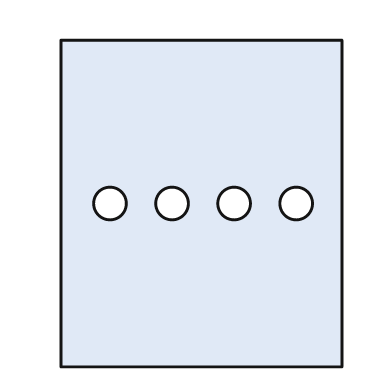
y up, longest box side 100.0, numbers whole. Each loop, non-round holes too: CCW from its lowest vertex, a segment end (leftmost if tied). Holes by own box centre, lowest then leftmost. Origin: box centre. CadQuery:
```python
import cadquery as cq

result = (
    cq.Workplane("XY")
    .moveTo(-43.0, -50.0)
    .lineTo(43.0, -50.0)
    .lineTo(43.0, 50.0)
    .lineTo(-43.0, 50.0)
    .close()
    .moveTo(-28.0, 0.0)
    .circle(5.0)
    .moveTo(-9.0, 0.0)
    .circle(5.0)
    .moveTo(10.0, 0.0)
    .circle(5.0)
    .moveTo(29.0, 0.0)
    .circle(5.0)
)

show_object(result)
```